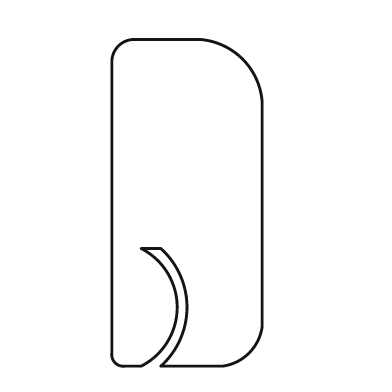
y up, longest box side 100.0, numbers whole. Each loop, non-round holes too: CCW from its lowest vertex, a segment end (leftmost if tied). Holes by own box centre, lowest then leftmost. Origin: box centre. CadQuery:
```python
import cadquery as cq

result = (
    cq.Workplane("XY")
    .moveTo(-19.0, -50.0)
    .lineTo(-14.0, -50.0)
    .threePointArc((-3.0, -32.0), (-14.0, -14.0))
    .lineTo(-8.0, -14.0)
    .threePointArc((0.0, -32.0), (-8.0, -50.0))
    .lineTo(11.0, -50.0)
    .threePointArc((19.0, -46.0), (23.0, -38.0))
    .lineTo(23.0, 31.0)
    .threePointArc((17.0, 44.0), (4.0, 50.0))
    .lineTo(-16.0, 50.0)
    .threePointArc((-21.0, 48.0), (-23.0, 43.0))
    .lineTo(-23.0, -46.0)
    .threePointArc((-22.0, -49.0), (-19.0, -50.0))
    .close()
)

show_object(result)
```